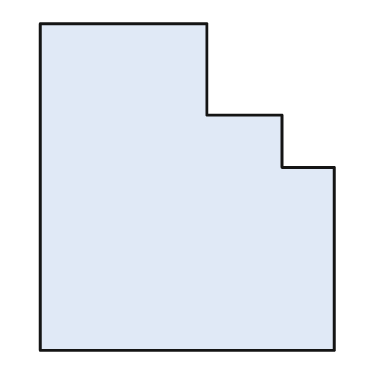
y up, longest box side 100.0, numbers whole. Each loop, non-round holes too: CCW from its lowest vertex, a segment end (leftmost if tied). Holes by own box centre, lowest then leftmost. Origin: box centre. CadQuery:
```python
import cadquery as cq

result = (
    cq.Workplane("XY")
    .moveTo(-45.0, -50.0)
    .lineTo(45.0, -50.0)
    .lineTo(45.0, 6.0)
    .lineTo(29.0, 6.0)
    .lineTo(29.0, 22.0)
    .lineTo(6.0, 22.0)
    .lineTo(6.0, 50.0)
    .lineTo(-45.0, 50.0)
    .close()
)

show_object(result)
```